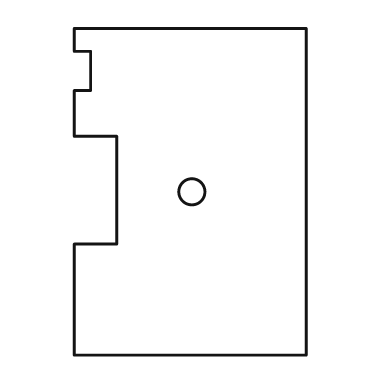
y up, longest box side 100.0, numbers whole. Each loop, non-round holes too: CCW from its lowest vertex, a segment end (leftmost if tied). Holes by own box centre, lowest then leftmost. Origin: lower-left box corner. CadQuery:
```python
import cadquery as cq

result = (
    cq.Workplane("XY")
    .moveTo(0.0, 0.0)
    .lineTo(71.0, 0.0)
    .lineTo(71.0, 100.0)
    .lineTo(0.0, 100.0)
    .lineTo(0.0, 93.0)
    .lineTo(5.0, 93.0)
    .lineTo(5.0, 81.0)
    .lineTo(0.0, 81.0)
    .lineTo(0.0, 67.0)
    .lineTo(13.0, 67.0)
    .lineTo(13.0, 34.0)
    .lineTo(0.0, 34.0)
    .close()
    .moveTo(36.0, 50.0)
    .circle(4.0)
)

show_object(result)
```